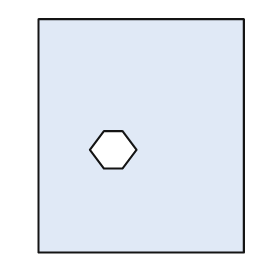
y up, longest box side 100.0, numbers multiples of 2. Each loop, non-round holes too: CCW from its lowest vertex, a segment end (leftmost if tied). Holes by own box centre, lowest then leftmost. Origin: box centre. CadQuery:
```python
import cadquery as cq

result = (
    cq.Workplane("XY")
    .moveTo(-44.0, -50.0)
    .lineTo(44.0, -50.0)
    .lineTo(44.0, 50.0)
    .lineTo(-44.0, 50.0)
    .close()
    .moveTo(-16.0, -14.0)
    .lineTo(-8.0, -14.0)
    .lineTo(-2.0, -6.0)
    .lineTo(-8.0, 2.0)
    .lineTo(-16.0, 2.0)
    .lineTo(-22.0, -6.0)
    .close()
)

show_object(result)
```